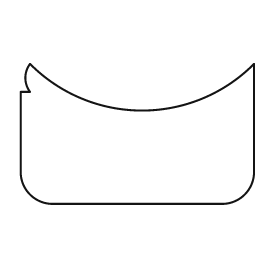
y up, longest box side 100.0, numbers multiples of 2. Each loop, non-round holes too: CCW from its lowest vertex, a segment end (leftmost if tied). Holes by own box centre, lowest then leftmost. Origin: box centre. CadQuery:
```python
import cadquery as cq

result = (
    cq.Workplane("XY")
    .moveTo(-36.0, -30.0)
    .lineTo(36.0, -30.0)
    .threePointArc((46.0, -26.0), (50.0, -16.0))
    .lineTo(50.0, 30.0)
    .threePointArc((2.0, 10.0), (-46.0, 30.0))
    .threePointArc((-48.0, 24.0), (-46.0, 18.0))
    .lineTo(-50.0, 18.0)
    .lineTo(-50.0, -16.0)
    .threePointArc((-46.0, -26.0), (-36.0, -30.0))
    .close()
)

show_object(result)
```